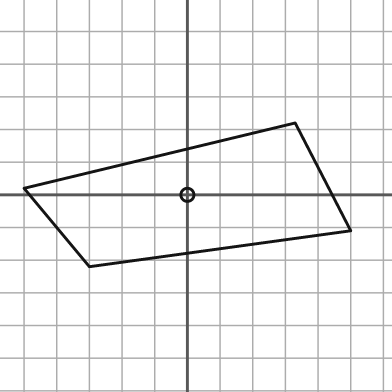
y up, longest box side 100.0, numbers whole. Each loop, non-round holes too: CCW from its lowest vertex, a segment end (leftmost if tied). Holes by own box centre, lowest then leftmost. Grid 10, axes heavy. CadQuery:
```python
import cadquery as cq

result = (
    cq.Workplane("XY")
    .moveTo(-30.0, -22.0)
    .lineTo(50.0, -11.0)
    .lineTo(33.0, 22.0)
    .lineTo(-50.0, 2.0)
    .close()
    .moveTo(0.0, 0.0)
    .circle(2.0)
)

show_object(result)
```